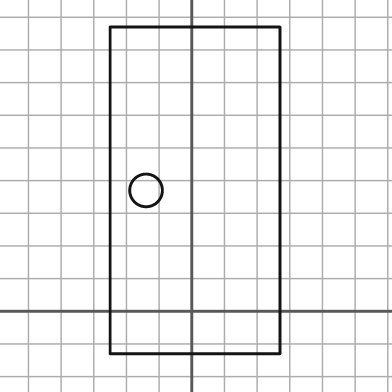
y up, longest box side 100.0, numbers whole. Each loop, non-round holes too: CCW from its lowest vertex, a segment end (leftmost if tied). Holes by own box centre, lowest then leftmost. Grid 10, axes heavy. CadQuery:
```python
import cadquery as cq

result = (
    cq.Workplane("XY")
    .moveTo(-25.0, -13.0)
    .lineTo(27.0, -13.0)
    .lineTo(27.0, 87.0)
    .lineTo(-25.0, 87.0)
    .close()
    .moveTo(-14.0, 37.0)
    .circle(5.0)
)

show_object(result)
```